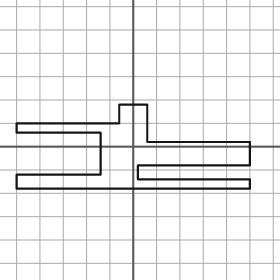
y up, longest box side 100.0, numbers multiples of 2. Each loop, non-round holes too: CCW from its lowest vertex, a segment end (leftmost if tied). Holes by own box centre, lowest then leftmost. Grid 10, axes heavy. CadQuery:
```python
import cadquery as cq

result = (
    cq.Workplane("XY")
    .moveTo(-50.0, -18.0)
    .lineTo(50.0, -18.0)
    .lineTo(50.0, -14.0)
    .lineTo(2.0, -14.0)
    .lineTo(2.0, -8.0)
    .lineTo(50.0, -8.0)
    .lineTo(50.0, 2.0)
    .lineTo(6.0, 2.0)
    .lineTo(6.0, 18.0)
    .lineTo(-6.0, 18.0)
    .lineTo(-6.0, 10.0)
    .lineTo(-50.0, 10.0)
    .lineTo(-50.0, 6.0)
    .lineTo(-14.0, 6.0)
    .lineTo(-14.0, -12.0)
    .lineTo(-50.0, -12.0)
    .close()
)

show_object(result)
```